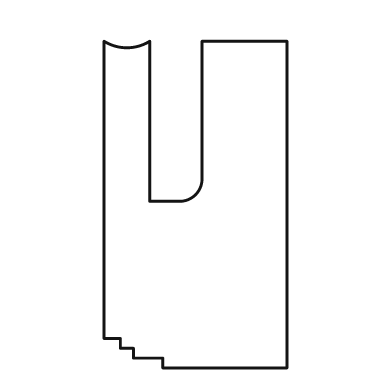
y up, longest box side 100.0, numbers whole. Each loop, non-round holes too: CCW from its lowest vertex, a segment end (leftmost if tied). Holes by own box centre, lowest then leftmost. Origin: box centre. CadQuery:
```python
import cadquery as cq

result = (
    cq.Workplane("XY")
    .moveTo(-10.0, -50.0)
    .lineTo(28.0, -50.0)
    .lineTo(28.0, 50.0)
    .lineTo(2.0, 50.0)
    .lineTo(2.0, 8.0)
    .threePointArc((0.0, 3.0), (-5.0, 1.0))
    .lineTo(-14.0, 1.0)
    .lineTo(-14.0, 50.0)
    .threePointArc((-21.0, 48.0), (-28.0, 50.0))
    .lineTo(-28.0, -41.0)
    .lineTo(-23.0, -41.0)
    .lineTo(-23.0, -44.0)
    .lineTo(-19.0, -44.0)
    .lineTo(-19.0, -47.0)
    .lineTo(-10.0, -47.0)
    .close()
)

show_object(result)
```